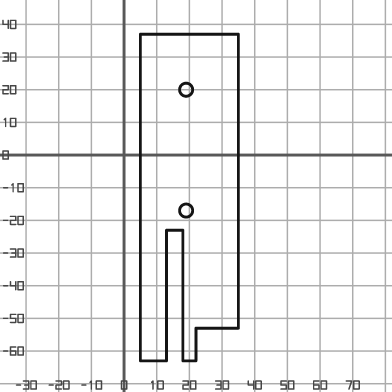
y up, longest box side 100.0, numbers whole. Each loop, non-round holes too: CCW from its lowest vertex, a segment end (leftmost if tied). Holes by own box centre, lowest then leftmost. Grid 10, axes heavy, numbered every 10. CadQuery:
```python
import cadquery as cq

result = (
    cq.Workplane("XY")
    .moveTo(5.0, -63.0)
    .lineTo(13.0, -63.0)
    .lineTo(13.0, -23.0)
    .lineTo(18.0, -23.0)
    .lineTo(18.0, -63.0)
    .lineTo(22.0, -63.0)
    .lineTo(22.0, -53.0)
    .lineTo(35.0, -53.0)
    .lineTo(35.0, 37.0)
    .lineTo(5.0, 37.0)
    .close()
    .moveTo(19.0, -17.0)
    .circle(2.0)
    .moveTo(19.0, 20.0)
    .circle(2.0)
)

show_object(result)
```